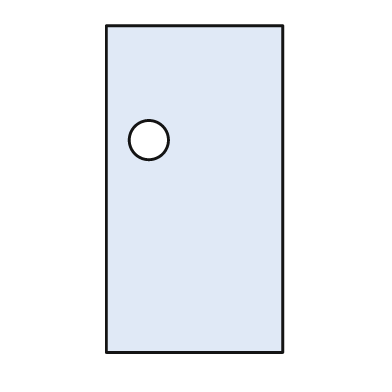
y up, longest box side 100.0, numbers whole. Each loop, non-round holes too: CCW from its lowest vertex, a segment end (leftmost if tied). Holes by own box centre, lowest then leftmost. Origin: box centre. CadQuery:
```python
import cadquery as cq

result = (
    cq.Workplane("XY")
    .moveTo(-27.0, -50.0)
    .lineTo(27.0, -50.0)
    .lineTo(27.0, 50.0)
    .lineTo(-27.0, 50.0)
    .close()
    .moveTo(-14.0, 15.0)
    .circle(6.0)
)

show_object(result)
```